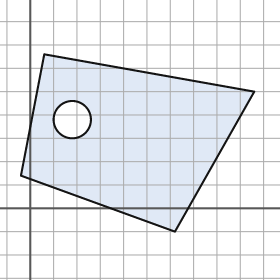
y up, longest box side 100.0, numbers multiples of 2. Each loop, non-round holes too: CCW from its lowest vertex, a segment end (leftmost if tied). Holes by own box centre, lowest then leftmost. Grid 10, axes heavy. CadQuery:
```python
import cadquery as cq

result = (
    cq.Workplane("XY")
    .moveTo(62.0, -10.0)
    .lineTo(96.0, 50.0)
    .lineTo(6.0, 66.0)
    .lineTo(-4.0, 14.0)
    .close()
    .moveTo(18.0, 38.0)
    .circle(8.0)
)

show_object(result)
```